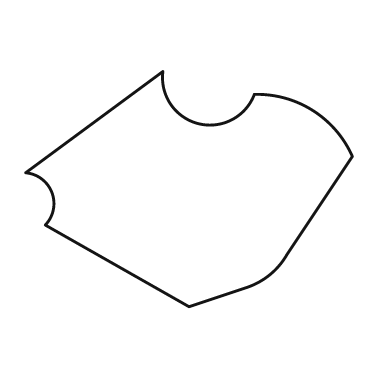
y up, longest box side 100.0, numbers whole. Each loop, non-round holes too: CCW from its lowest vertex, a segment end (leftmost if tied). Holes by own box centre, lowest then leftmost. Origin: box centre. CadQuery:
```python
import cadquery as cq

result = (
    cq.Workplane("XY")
    .moveTo(0.0, -36.0)
    .lineTo(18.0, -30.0)
    .threePointArc((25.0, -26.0), (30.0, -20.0))
    .lineTo(50.0, 10.0)
    .threePointArc((38.0, 24.0), (20.0, 29.0))
    .threePointArc((3.0, 20.0), (-8.0, 36.0))
    .lineTo(-50.0, 5.0)
    .threePointArc((-42.0, -1.0), (-44.0, -11.0))
    .close()
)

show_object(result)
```